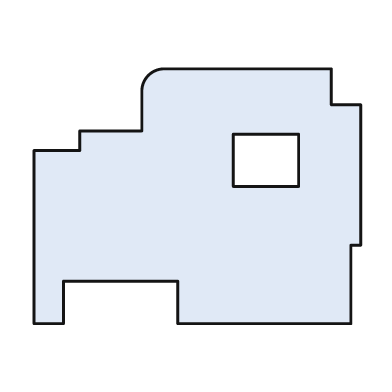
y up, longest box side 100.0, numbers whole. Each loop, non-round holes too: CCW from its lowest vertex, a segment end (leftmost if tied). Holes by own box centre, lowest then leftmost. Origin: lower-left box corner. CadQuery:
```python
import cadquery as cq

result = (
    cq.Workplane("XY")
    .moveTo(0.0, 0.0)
    .lineTo(9.0, 0.0)
    .lineTo(9.0, 13.0)
    .lineTo(44.0, 13.0)
    .lineTo(44.0, 0.0)
    .lineTo(97.0, 0.0)
    .lineTo(97.0, 24.0)
    .lineTo(100.0, 24.0)
    .lineTo(100.0, 67.0)
    .lineTo(91.0, 67.0)
    .lineTo(91.0, 78.0)
    .lineTo(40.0, 78.0)
    .threePointArc((35.0, 76.0), (33.0, 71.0))
    .lineTo(33.0, 59.0)
    .lineTo(14.0, 59.0)
    .lineTo(14.0, 53.0)
    .lineTo(0.0, 53.0)
    .close()
    .moveTo(61.0, 42.0)
    .lineTo(81.0, 42.0)
    .lineTo(81.0, 58.0)
    .lineTo(61.0, 58.0)
    .close()
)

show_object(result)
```